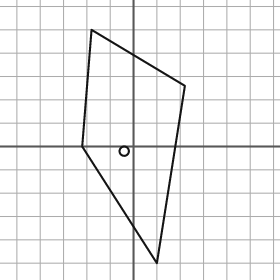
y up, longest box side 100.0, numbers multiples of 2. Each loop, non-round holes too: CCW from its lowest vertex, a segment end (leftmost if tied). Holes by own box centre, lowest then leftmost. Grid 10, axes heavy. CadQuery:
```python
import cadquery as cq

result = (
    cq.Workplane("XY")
    .moveTo(10.0, -50.0)
    .lineTo(22.0, 26.0)
    .lineTo(-18.0, 50.0)
    .lineTo(-22.0, 0.0)
    .close()
    .moveTo(-4.0, -2.0)
    .circle(2.0)
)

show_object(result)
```